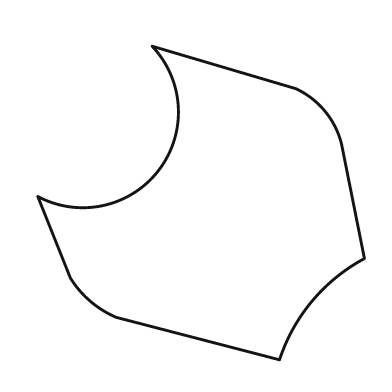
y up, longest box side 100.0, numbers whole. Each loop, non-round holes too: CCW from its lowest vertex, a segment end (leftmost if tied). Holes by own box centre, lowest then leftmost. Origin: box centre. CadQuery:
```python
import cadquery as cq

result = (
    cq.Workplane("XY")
    .moveTo(24.0, -48.0)
    .threePointArc((34.0, -30.0), (50.0, -17.0))
    .lineTo(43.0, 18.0)
    .threePointArc((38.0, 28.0), (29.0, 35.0))
    .lineTo(-15.0, 48.0)
    .threePointArc((-13.0, 10.0), (-50.0, 2.0))
    .lineTo(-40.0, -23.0)
    .threePointArc((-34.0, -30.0), (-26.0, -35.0))
    .close()
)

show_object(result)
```